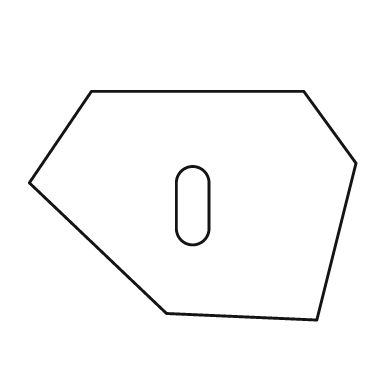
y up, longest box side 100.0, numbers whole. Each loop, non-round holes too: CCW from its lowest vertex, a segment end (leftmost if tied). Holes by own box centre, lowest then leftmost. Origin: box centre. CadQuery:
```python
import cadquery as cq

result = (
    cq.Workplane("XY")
    .moveTo(38.0, -35.0)
    .lineTo(50.0, 13.0)
    .lineTo(34.0, 35.0)
    .lineTo(-31.0, 35.0)
    .lineTo(-50.0, 7.0)
    .lineTo(-8.0, -33.0)
    .close()
    .moveTo(-5.0, -7.0)
    .threePointArc((0.0, -12.0), (5.0, -7.0))
    .lineTo(5.0, 7.0)
    .threePointArc((0.0, 12.0), (-5.0, 7.0))
    .close()
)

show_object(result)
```